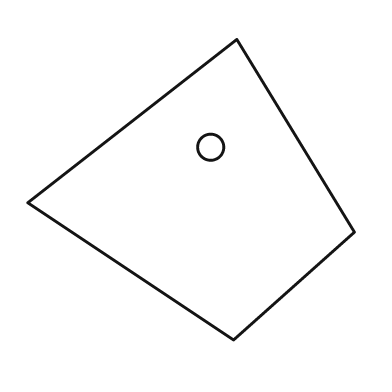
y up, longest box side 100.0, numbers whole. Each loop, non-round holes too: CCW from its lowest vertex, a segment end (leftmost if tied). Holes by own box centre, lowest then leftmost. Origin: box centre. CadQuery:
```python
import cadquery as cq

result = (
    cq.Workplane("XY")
    .moveTo(13.0, -46.0)
    .lineTo(50.0, -13.0)
    .lineTo(14.0, 46.0)
    .lineTo(-50.0, -4.0)
    .close()
    .moveTo(6.0, 13.0)
    .circle(4.0)
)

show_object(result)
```